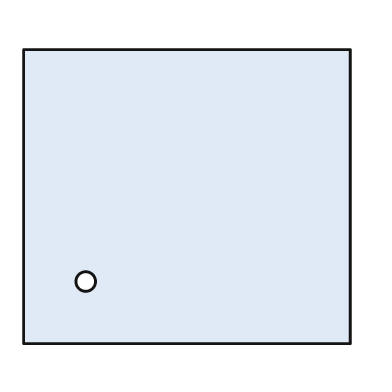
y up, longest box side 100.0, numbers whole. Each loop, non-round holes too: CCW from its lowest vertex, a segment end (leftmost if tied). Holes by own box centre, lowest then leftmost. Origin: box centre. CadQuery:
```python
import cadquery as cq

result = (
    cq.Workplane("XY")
    .moveTo(-50.0, -45.0)
    .lineTo(50.0, -45.0)
    .lineTo(50.0, 45.0)
    .lineTo(-50.0, 45.0)
    .close()
    .moveTo(-31.0, -26.0)
    .circle(3.0)
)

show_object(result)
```